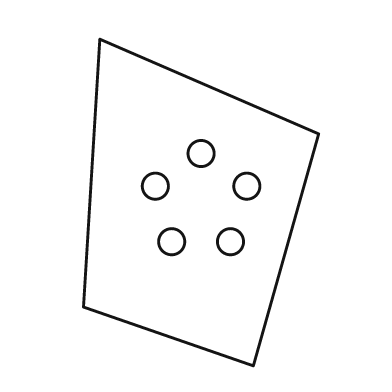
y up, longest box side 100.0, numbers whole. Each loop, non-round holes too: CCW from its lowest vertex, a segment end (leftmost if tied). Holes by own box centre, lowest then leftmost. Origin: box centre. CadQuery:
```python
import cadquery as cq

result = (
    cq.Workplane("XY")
    .moveTo(16.0, -50.0)
    .lineTo(36.0, 21.0)
    .lineTo(-31.0, 50.0)
    .lineTo(-36.0, -32.0)
    .close()
    .moveTo(-9.0, -12.0)
    .circle(4.0)
    .moveTo(9.0, -12.0)
    .circle(4.0)
    .moveTo(-14.0, 5.0)
    .circle(4.0)
    .moveTo(14.0, 5.0)
    .circle(4.0)
    .moveTo(0.0, 15.0)
    .circle(4.0)
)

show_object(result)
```